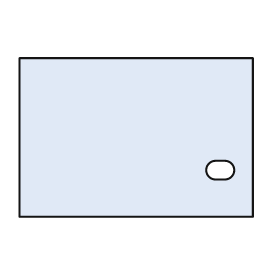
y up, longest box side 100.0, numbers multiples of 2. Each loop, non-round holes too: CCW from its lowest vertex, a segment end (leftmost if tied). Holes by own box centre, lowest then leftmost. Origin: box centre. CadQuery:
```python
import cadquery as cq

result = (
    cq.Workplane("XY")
    .moveTo(-50.0, -34.0)
    .lineTo(50.0, -34.0)
    .lineTo(50.0, 34.0)
    .lineTo(-50.0, 34.0)
    .close()
    .moveTo(34.0, -18.0)
    .lineTo(38.0, -18.0)
    .threePointArc((42.0, -14.0), (38.0, -10.0))
    .lineTo(34.0, -10.0)
    .threePointArc((30.0, -14.0), (34.0, -18.0))
    .close()
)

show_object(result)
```